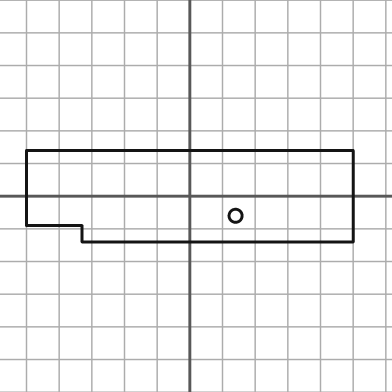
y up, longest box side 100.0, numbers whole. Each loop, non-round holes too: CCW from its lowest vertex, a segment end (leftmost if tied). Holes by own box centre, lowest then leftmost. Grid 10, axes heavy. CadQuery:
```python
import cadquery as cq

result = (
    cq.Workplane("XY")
    .moveTo(-33.0, -14.0)
    .lineTo(50.0, -14.0)
    .lineTo(50.0, 14.0)
    .lineTo(-50.0, 14.0)
    .lineTo(-50.0, -9.0)
    .lineTo(-33.0, -9.0)
    .close()
    .moveTo(14.0, -6.0)
    .circle(2.0)
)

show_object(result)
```